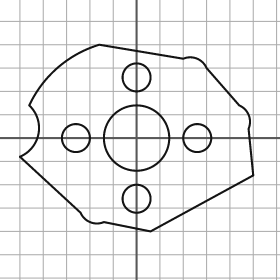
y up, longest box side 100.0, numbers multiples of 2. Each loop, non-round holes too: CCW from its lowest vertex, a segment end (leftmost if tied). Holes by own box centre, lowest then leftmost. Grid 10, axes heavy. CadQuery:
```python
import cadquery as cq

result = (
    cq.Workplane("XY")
    .moveTo(6.0, -40.0)
    .lineTo(50.0, -16.0)
    .lineTo(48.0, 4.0)
    .threePointArc((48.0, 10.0), (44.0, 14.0))
    .lineTo(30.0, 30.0)
    .threePointArc((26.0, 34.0), (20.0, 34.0))
    .lineTo(-16.0, 40.0)
    .threePointArc((-34.0, 30.0), (-46.0, 14.0))
    .threePointArc((-42.0, 2.0), (-50.0, -8.0))
    .lineTo(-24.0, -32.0)
    .threePointArc((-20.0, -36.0), (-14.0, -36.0))
    .close()
    .moveTo(0.0, -26.0)
    .circle(6.0)
    .moveTo(-26.0, 0.0)
    .circle(6.0)
    .moveTo(0.0, 0.0)
    .circle(14.0)
    .moveTo(26.0, 0.0)
    .circle(6.0)
    .moveTo(0.0, 26.0)
    .circle(6.0)
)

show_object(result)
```